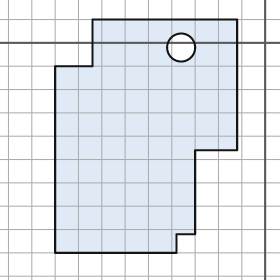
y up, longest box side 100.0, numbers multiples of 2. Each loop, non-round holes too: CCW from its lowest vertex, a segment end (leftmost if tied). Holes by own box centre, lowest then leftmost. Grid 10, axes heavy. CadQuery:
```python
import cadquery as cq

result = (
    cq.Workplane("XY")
    .moveTo(-90.0, -90.0)
    .lineTo(-38.0, -90.0)
    .lineTo(-38.0, -82.0)
    .lineTo(-30.0, -82.0)
    .lineTo(-30.0, -46.0)
    .lineTo(-12.0, -46.0)
    .lineTo(-12.0, 10.0)
    .lineTo(-74.0, 10.0)
    .lineTo(-74.0, -10.0)
    .lineTo(-90.0, -10.0)
    .close()
    .moveTo(-36.0, -2.0)
    .circle(6.0)
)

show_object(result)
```